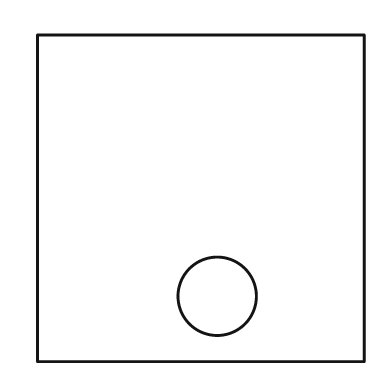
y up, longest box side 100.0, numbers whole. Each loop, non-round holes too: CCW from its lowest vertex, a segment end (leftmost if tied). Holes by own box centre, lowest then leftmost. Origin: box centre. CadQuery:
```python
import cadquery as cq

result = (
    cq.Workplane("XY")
    .moveTo(-50.0, -50.0)
    .lineTo(50.0, -50.0)
    .lineTo(50.0, 50.0)
    .lineTo(-50.0, 50.0)
    .close()
    .moveTo(5.0, -30.0)
    .circle(12.0)
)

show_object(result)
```